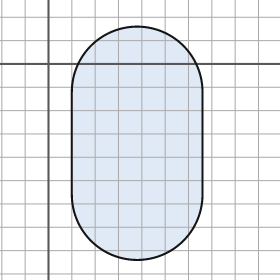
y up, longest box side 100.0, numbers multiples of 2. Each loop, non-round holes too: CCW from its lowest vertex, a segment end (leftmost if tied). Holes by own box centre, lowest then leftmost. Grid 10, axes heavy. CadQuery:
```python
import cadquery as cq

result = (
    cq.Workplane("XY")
    .moveTo(10.0, -56.0)
    .threePointArc((38.0, -84.0), (66.0, -56.0))
    .lineTo(66.0, -12.0)
    .threePointArc((38.0, 16.0), (10.0, -12.0))
    .close()
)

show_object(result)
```